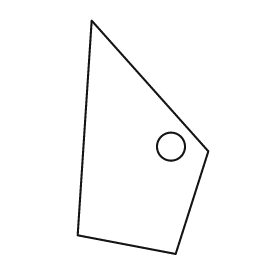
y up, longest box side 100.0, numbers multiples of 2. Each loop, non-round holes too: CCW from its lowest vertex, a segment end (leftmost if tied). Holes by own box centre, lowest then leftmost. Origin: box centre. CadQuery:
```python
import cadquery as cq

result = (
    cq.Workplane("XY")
    .moveTo(14.0, -50.0)
    .lineTo(28.0, -6.0)
    .lineTo(-22.0, 50.0)
    .lineTo(-28.0, -42.0)
    .close()
    .moveTo(12.0, -4.0)
    .circle(6.0)
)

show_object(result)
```